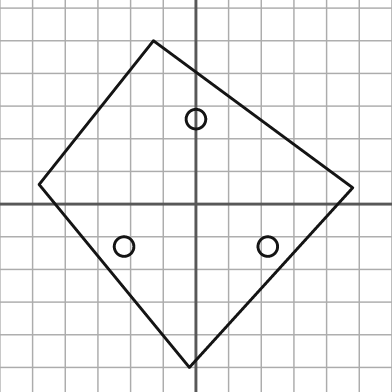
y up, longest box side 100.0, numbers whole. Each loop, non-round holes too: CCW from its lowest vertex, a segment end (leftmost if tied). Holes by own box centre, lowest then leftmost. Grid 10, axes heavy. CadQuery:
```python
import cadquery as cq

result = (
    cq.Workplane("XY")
    .moveTo(-2.0, -50.0)
    .lineTo(48.0, 5.0)
    .lineTo(-13.0, 50.0)
    .lineTo(-48.0, 6.0)
    .close()
    .moveTo(-22.0, -13.0)
    .circle(3.0)
    .moveTo(22.0, -13.0)
    .circle(3.0)
    .moveTo(0.0, 26.0)
    .circle(3.0)
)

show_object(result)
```